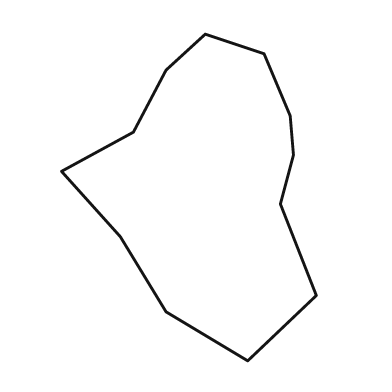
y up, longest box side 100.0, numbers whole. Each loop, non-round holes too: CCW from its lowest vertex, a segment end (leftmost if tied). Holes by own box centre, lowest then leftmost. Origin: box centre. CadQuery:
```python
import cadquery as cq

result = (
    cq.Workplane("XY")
    .moveTo(18.0, -50.0)
    .lineTo(39.0, -30.0)
    .lineTo(28.0, -2.0)
    .lineTo(32.0, 13.0)
    .lineTo(31.0, 25.0)
    .lineTo(23.0, 44.0)
    .lineTo(5.0, 50.0)
    .lineTo(-7.0, 39.0)
    .lineTo(-17.0, 20.0)
    .lineTo(-39.0, 8.0)
    .lineTo(-21.0, -12.0)
    .lineTo(-7.0, -35.0)
    .close()
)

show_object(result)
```